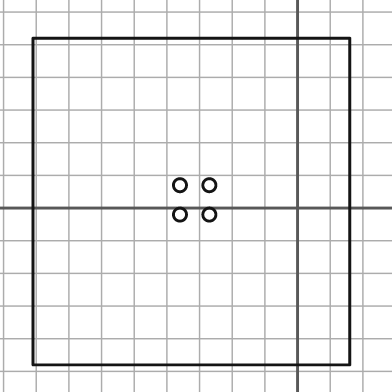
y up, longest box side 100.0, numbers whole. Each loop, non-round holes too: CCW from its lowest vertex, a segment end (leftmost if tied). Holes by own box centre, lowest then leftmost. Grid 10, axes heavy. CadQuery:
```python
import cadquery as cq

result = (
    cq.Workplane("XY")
    .moveTo(-81.0, -48.0)
    .lineTo(16.0, -48.0)
    .lineTo(16.0, 52.0)
    .lineTo(-81.0, 52.0)
    .close()
    .moveTo(-36.0, -2.0)
    .circle(2.0)
    .moveTo(-27.0, -2.0)
    .circle(2.0)
    .moveTo(-36.0, 7.0)
    .circle(2.0)
    .moveTo(-27.0, 7.0)
    .circle(2.0)
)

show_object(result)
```